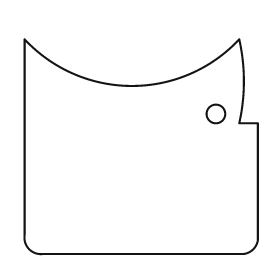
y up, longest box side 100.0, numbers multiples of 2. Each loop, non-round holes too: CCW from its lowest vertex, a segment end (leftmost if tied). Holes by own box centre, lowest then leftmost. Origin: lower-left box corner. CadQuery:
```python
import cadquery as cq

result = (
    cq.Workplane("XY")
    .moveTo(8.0, 0.0)
    .lineTo(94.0, 0.0)
    .threePointArc((98.0, 2.0), (100.0, 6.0))
    .lineTo(100.0, 56.0)
    .lineTo(92.0, 56.0)
    .threePointArc((94.0, 74.0), (92.0, 92.0))
    .threePointArc((46.0, 72.0), (0.0, 92.0))
    .lineTo(0.0, 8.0)
    .threePointArc((2.0, 2.0), (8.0, 0.0))
    .close()
    .moveTo(82.0, 60.0)
    .circle(4.0)
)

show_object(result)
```